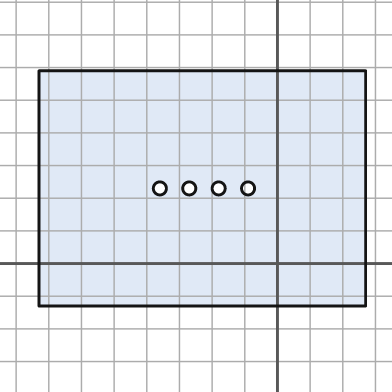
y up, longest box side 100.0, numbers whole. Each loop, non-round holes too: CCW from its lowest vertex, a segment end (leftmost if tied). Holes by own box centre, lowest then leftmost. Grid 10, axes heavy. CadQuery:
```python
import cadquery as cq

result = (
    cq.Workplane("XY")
    .moveTo(-73.0, -13.0)
    .lineTo(27.0, -13.0)
    .lineTo(27.0, 59.0)
    .lineTo(-73.0, 59.0)
    .close()
    .moveTo(-36.0, 23.0)
    .circle(2.0)
    .moveTo(-27.0, 23.0)
    .circle(2.0)
    .moveTo(-18.0, 23.0)
    .circle(2.0)
    .moveTo(-9.0, 23.0)
    .circle(2.0)
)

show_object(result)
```